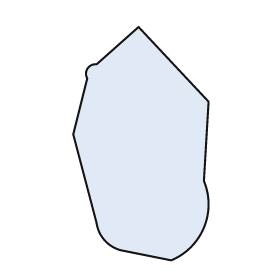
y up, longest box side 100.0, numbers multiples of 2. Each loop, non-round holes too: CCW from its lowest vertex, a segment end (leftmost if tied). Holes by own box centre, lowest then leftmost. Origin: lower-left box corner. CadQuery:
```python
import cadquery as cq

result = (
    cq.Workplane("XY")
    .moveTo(42.0, 0.0)
    .threePointArc((56.0, 14.0), (56.0, 34.0))
    .lineTo(58.0, 68.0)
    .lineTo(28.0, 100.0)
    .lineTo(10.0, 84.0)
    .threePointArc((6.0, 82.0), (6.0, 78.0))
    .lineTo(0.0, 54.0)
    .lineTo(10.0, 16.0)
    .threePointArc((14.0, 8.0), (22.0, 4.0))
    .close()
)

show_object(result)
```